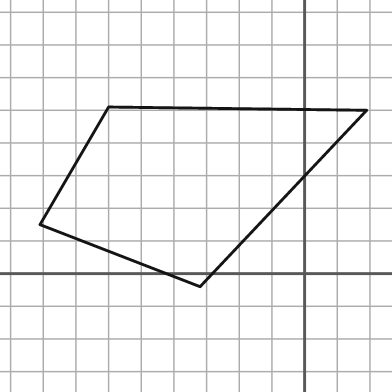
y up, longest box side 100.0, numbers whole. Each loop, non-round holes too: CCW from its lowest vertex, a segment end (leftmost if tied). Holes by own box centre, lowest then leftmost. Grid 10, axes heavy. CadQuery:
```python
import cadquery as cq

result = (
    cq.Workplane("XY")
    .moveTo(-32.0, -4.0)
    .lineTo(19.0, 50.0)
    .lineTo(-60.0, 51.0)
    .lineTo(-81.0, 15.0)
    .close()
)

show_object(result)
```